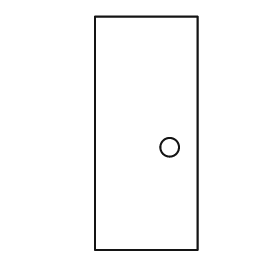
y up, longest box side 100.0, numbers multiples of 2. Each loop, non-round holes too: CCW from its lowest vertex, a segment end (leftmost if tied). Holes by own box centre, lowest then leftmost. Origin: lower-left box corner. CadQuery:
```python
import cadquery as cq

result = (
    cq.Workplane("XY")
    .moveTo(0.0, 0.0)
    .lineTo(44.0, 0.0)
    .lineTo(44.0, 100.0)
    .lineTo(0.0, 100.0)
    .close()
    .moveTo(32.0, 44.0)
    .circle(4.0)
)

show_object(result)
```